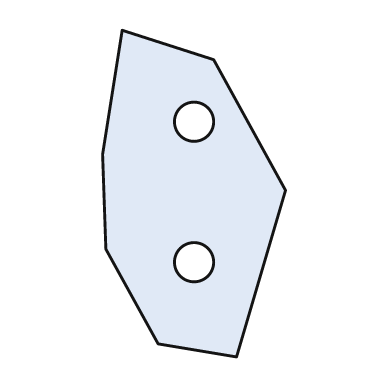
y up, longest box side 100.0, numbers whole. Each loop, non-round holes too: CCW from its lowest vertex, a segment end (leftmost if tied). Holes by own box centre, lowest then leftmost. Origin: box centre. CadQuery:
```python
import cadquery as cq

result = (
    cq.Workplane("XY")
    .moveTo(13.0, -50.0)
    .lineTo(28.0, 1.0)
    .lineTo(6.0, 41.0)
    .lineTo(-22.0, 50.0)
    .lineTo(-28.0, 12.0)
    .lineTo(-27.0, -17.0)
    .lineTo(-11.0, -46.0)
    .close()
    .moveTo(0.0, -21.0)
    .circle(6.0)
    .moveTo(0.0, 22.0)
    .circle(6.0)
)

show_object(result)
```